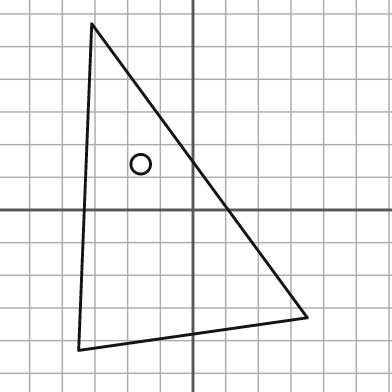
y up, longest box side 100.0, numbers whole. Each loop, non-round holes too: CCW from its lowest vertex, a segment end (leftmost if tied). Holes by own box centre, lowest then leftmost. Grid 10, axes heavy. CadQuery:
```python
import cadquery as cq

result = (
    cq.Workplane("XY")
    .moveTo(-35.0, -43.0)
    .lineTo(35.0, -33.0)
    .lineTo(-31.0, 57.0)
    .close()
    .moveTo(-16.0, 14.0)
    .circle(3.0)
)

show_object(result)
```